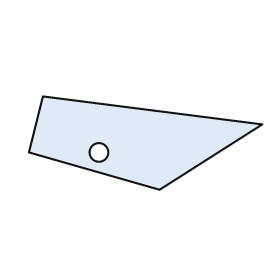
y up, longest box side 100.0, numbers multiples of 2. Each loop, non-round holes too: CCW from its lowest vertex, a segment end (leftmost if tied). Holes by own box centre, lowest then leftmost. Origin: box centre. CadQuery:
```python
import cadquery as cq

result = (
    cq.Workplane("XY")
    .moveTo(6.0, -20.0)
    .lineTo(50.0, 8.0)
    .lineTo(-44.0, 20.0)
    .lineTo(-50.0, -4.0)
    .close()
    .moveTo(-20.0, -4.0)
    .circle(4.0)
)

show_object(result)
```